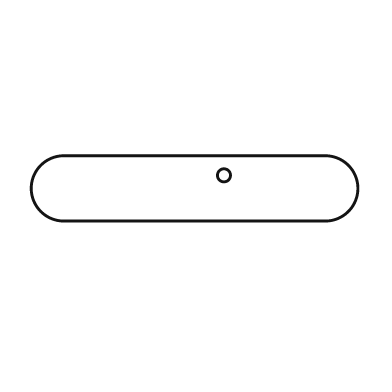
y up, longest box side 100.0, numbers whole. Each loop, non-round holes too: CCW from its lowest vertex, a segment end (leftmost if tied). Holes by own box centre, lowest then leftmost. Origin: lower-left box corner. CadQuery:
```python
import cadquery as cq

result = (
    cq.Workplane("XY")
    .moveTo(10.0, 0.0)
    .lineTo(90.0, 0.0)
    .threePointArc((100.0, 10.0), (90.0, 20.0))
    .lineTo(10.0, 20.0)
    .threePointArc((0.0, 10.0), (10.0, 0.0))
    .close()
    .moveTo(59.0, 14.0)
    .circle(2.0)
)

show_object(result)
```